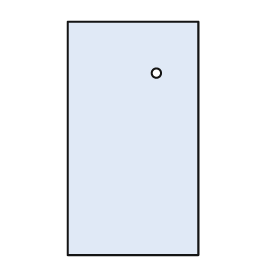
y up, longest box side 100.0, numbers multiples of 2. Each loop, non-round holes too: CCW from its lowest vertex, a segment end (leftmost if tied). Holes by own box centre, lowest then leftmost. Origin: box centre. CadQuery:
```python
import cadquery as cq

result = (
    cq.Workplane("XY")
    .moveTo(-28.0, -50.0)
    .lineTo(28.0, -50.0)
    .lineTo(28.0, 50.0)
    .lineTo(-28.0, 50.0)
    .close()
    .moveTo(10.0, 28.0)
    .circle(2.0)
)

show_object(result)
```